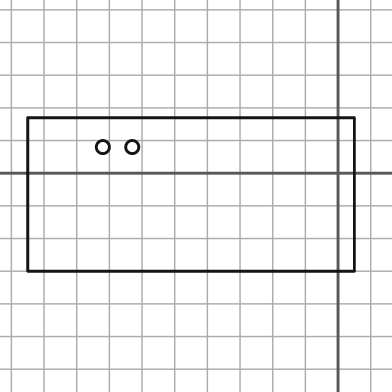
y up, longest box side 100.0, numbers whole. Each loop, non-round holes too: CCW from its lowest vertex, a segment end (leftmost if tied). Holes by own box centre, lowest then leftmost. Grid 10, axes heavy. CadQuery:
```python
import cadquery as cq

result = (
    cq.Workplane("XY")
    .moveTo(-95.0, -30.0)
    .lineTo(5.0, -30.0)
    .lineTo(5.0, 17.0)
    .lineTo(-95.0, 17.0)
    .close()
    .moveTo(-72.0, 8.0)
    .circle(2.0)
    .moveTo(-63.0, 8.0)
    .circle(2.0)
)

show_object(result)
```